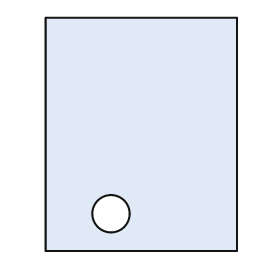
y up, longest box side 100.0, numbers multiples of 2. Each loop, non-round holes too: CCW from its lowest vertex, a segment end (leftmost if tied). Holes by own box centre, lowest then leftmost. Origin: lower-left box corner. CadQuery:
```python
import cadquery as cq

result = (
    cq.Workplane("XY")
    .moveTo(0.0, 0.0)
    .lineTo(82.0, 0.0)
    .lineTo(82.0, 100.0)
    .lineTo(0.0, 100.0)
    .close()
    .moveTo(28.0, 16.0)
    .circle(8.0)
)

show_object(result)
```